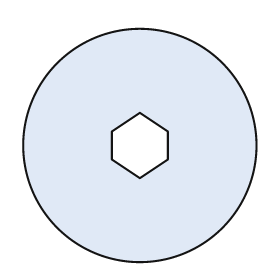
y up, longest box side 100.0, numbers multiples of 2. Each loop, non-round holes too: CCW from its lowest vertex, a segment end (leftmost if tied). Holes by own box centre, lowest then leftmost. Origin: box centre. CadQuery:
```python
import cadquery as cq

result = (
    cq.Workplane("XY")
    .moveTo(0.0, 0.0)
    .circle(50.0)
    .moveTo(0.0, -14.0)
    .lineTo(12.0, -6.0)
    .lineTo(12.0, 6.0)
    .lineTo(0.0, 14.0)
    .lineTo(-12.0, 6.0)
    .lineTo(-12.0, -6.0)
    .close()
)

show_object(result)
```